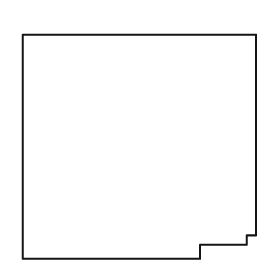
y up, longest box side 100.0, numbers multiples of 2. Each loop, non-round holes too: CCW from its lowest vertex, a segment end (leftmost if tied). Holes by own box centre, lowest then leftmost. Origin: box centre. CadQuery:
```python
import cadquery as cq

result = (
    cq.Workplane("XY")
    .moveTo(-50.0, -48.0)
    .lineTo(26.0, -48.0)
    .lineTo(26.0, -42.0)
    .lineTo(46.0, -42.0)
    .lineTo(46.0, -38.0)
    .lineTo(50.0, -38.0)
    .lineTo(50.0, 48.0)
    .lineTo(-50.0, 48.0)
    .close()
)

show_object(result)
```